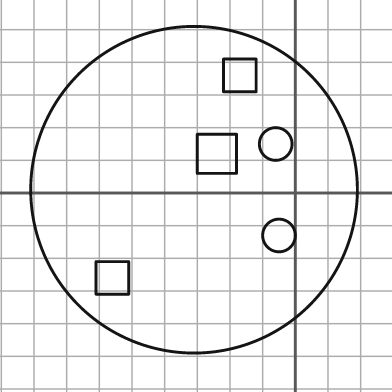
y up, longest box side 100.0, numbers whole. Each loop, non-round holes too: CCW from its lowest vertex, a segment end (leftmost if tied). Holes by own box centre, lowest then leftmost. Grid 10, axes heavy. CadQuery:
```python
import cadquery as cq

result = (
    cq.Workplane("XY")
    .moveTo(-31.0, 1.0)
    .circle(50.0)
    .moveTo(-61.0, -31.0)
    .lineTo(-51.0, -31.0)
    .lineTo(-51.0, -21.0)
    .lineTo(-61.0, -21.0)
    .close()
    .moveTo(-5.0, -13.0)
    .circle(5.0)
    .moveTo(-30.0, 6.0)
    .lineTo(-18.0, 6.0)
    .lineTo(-18.0, 18.0)
    .lineTo(-30.0, 18.0)
    .close()
    .moveTo(-6.0, 15.0)
    .circle(5.0)
    .moveTo(-22.0, 31.0)
    .lineTo(-12.0, 31.0)
    .lineTo(-12.0, 41.0)
    .lineTo(-22.0, 41.0)
    .close()
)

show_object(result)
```